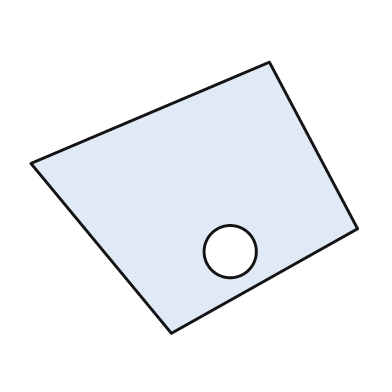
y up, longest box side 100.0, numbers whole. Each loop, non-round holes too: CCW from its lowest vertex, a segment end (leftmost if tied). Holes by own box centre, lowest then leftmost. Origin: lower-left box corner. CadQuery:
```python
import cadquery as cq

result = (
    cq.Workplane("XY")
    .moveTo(43.0, 0.0)
    .lineTo(100.0, 32.0)
    .lineTo(73.0, 83.0)
    .lineTo(0.0, 52.0)
    .close()
    .moveTo(61.0, 25.0)
    .circle(8.0)
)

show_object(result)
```